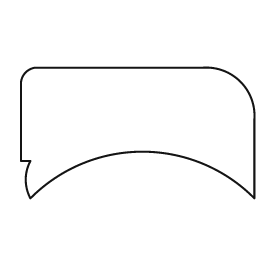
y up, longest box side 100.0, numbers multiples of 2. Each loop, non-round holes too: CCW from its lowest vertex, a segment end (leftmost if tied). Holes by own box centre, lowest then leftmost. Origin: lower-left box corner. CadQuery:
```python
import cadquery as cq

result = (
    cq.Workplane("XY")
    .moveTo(4.0, 0.0)
    .threePointArc((52.0, 20.0), (100.0, 0.0))
    .lineTo(100.0, 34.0)
    .threePointArc((94.0, 50.0), (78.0, 56.0))
    .lineTo(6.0, 56.0)
    .threePointArc((2.0, 54.0), (0.0, 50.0))
    .lineTo(0.0, 16.0)
    .lineTo(4.0, 16.0)
    .threePointArc((2.0, 8.0), (4.0, 0.0))
    .close()
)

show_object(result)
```